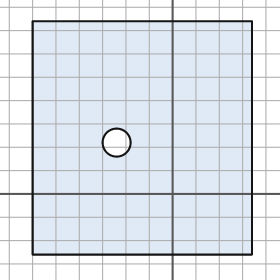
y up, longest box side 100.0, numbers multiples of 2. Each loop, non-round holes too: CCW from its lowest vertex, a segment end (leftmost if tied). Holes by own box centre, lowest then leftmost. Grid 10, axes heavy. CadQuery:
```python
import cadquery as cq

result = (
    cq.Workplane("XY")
    .moveTo(-60.0, -26.0)
    .lineTo(34.0, -26.0)
    .lineTo(34.0, 74.0)
    .lineTo(-60.0, 74.0)
    .close()
    .moveTo(-24.0, 22.0)
    .circle(6.0)
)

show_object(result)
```